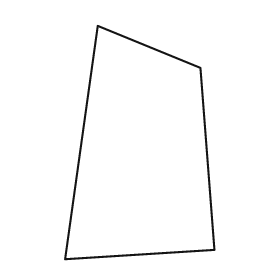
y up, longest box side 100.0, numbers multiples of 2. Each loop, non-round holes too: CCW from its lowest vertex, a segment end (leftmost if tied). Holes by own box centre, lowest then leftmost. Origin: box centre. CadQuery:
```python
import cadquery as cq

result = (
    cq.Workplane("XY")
    .moveTo(-32.0, -50.0)
    .lineTo(32.0, -46.0)
    .lineTo(26.0, 32.0)
    .lineTo(-18.0, 50.0)
    .close()
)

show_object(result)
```